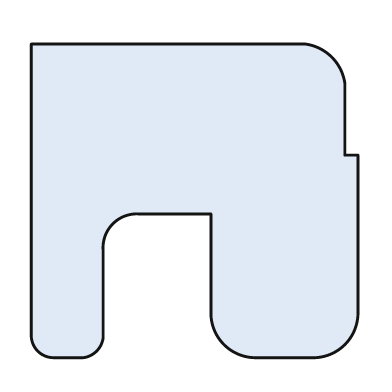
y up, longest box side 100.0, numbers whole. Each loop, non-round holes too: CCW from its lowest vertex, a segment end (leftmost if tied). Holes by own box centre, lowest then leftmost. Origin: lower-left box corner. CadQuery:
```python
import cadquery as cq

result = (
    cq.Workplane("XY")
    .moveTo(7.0, 0.0)
    .lineTo(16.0, 0.0)
    .threePointArc((20.0, 2.0), (22.0, 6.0))
    .lineTo(22.0, 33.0)
    .threePointArc((25.0, 41.0), (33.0, 44.0))
    .lineTo(55.0, 44.0)
    .lineTo(55.0, 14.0)
    .threePointArc((59.0, 4.0), (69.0, 0.0))
    .lineTo(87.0, 0.0)
    .threePointArc((96.0, 4.0), (100.0, 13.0))
    .lineTo(100.0, 62.0)
    .lineTo(96.0, 62.0)
    .lineTo(96.0, 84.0)
    .threePointArc((92.0, 92.0), (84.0, 96.0))
    .lineTo(0.0, 96.0)
    .lineTo(0.0, 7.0)
    .threePointArc((2.0, 2.0), (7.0, 0.0))
    .close()
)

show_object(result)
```